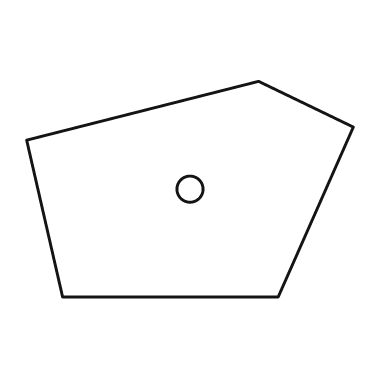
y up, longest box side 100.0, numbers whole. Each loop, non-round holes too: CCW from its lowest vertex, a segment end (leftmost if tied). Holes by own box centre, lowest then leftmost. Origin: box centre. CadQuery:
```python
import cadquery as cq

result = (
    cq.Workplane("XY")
    .moveTo(-39.0, -33.0)
    .lineTo(27.0, -33.0)
    .lineTo(50.0, 19.0)
    .lineTo(21.0, 33.0)
    .lineTo(-50.0, 15.0)
    .close()
    .moveTo(0.0, 0.0)
    .circle(4.0)
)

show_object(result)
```